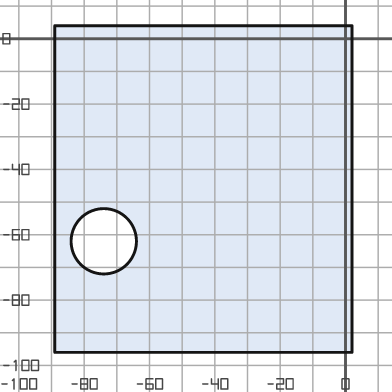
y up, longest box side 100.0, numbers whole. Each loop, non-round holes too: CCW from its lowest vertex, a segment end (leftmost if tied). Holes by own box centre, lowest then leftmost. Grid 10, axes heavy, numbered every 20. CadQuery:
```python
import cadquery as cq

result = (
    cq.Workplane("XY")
    .moveTo(-89.0, -96.0)
    .lineTo(2.0, -96.0)
    .lineTo(2.0, 4.0)
    .lineTo(-89.0, 4.0)
    .close()
    .moveTo(-74.0, -62.0)
    .circle(10.0)
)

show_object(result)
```